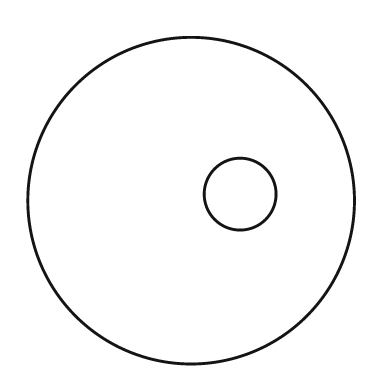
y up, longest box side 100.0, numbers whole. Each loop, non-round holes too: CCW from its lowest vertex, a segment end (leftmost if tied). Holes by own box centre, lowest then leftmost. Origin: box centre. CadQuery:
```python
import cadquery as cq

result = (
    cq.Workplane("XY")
    .moveTo(0.0, 0.0)
    .circle(50.0)
    .moveTo(15.0, 2.0)
    .circle(11.0)
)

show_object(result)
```